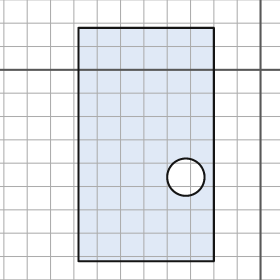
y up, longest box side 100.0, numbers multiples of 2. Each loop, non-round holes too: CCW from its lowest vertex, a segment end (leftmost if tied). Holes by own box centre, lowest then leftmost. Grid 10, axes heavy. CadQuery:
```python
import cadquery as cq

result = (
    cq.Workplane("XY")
    .moveTo(-78.0, -82.0)
    .lineTo(-20.0, -82.0)
    .lineTo(-20.0, 18.0)
    .lineTo(-78.0, 18.0)
    .close()
    .moveTo(-32.0, -46.0)
    .circle(8.0)
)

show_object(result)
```